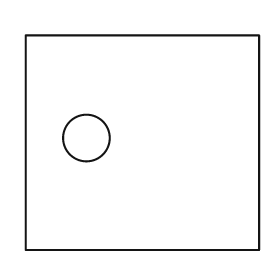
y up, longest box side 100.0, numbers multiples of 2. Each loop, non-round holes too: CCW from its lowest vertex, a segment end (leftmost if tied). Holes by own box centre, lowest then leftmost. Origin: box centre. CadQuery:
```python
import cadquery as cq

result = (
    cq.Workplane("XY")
    .moveTo(-50.0, -46.0)
    .lineTo(50.0, -46.0)
    .lineTo(50.0, 46.0)
    .lineTo(-50.0, 46.0)
    .close()
    .moveTo(-24.0, 2.0)
    .circle(10.0)
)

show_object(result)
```